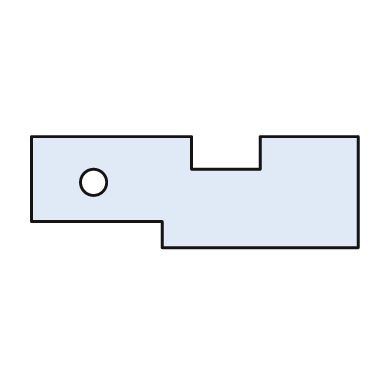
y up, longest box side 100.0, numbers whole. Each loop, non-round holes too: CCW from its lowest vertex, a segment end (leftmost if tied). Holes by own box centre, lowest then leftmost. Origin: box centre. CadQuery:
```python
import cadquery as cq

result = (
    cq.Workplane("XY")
    .moveTo(-10.0, -17.0)
    .lineTo(50.0, -17.0)
    .lineTo(50.0, 17.0)
    .lineTo(20.0, 17.0)
    .lineTo(20.0, 7.0)
    .lineTo(-1.0, 7.0)
    .lineTo(-1.0, 17.0)
    .lineTo(-50.0, 17.0)
    .lineTo(-50.0, -9.0)
    .lineTo(-10.0, -9.0)
    .close()
    .moveTo(-31.0, 3.0)
    .circle(4.0)
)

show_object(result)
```